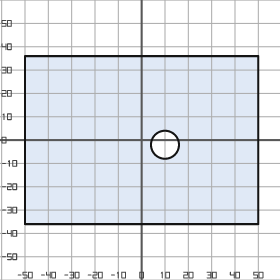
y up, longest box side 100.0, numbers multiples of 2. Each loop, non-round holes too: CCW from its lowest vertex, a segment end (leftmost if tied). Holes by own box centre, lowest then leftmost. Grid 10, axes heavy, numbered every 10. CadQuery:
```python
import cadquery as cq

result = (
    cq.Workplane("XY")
    .moveTo(-50.0, -36.0)
    .lineTo(50.0, -36.0)
    .lineTo(50.0, 36.0)
    .lineTo(-50.0, 36.0)
    .close()
    .moveTo(10.0, -2.0)
    .circle(6.0)
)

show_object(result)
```